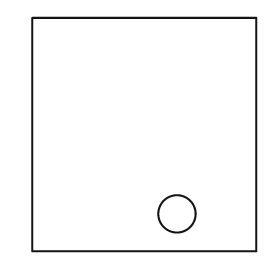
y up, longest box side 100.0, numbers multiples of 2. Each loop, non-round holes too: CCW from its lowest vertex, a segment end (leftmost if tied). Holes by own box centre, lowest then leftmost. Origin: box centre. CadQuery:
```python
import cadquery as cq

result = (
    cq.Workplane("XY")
    .moveTo(-48.0, -50.0)
    .lineTo(48.0, -50.0)
    .lineTo(48.0, 50.0)
    .lineTo(-48.0, 50.0)
    .close()
    .moveTo(14.0, -34.0)
    .circle(8.0)
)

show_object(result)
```